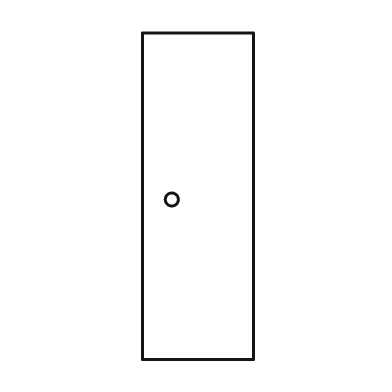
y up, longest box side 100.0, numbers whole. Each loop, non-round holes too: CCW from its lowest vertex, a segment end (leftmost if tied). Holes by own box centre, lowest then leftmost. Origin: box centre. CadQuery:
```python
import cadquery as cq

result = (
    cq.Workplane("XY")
    .moveTo(-17.0, -50.0)
    .lineTo(17.0, -50.0)
    .lineTo(17.0, 50.0)
    .lineTo(-17.0, 50.0)
    .close()
    .moveTo(-8.0, -1.0)
    .circle(2.0)
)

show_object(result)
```